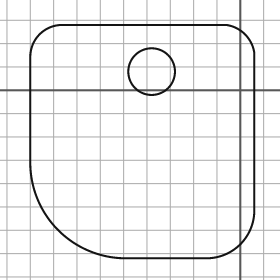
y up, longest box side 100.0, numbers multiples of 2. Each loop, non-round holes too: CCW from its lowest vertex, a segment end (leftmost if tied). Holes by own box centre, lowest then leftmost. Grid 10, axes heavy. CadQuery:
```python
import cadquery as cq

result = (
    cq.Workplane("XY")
    .moveTo(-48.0, -72.0)
    .lineTo(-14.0, -72.0)
    .threePointArc((0.0, -66.0), (6.0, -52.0))
    .lineTo(6.0, 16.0)
    .threePointArc((2.0, 24.0), (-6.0, 28.0))
    .lineTo(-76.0, 28.0)
    .threePointArc((-86.0, 24.0), (-90.0, 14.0))
    .lineTo(-90.0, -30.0)
    .threePointArc((-78.0, -60.0), (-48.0, -72.0))
    .close()
    .moveTo(-38.0, 8.0)
    .circle(10.0)
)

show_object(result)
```